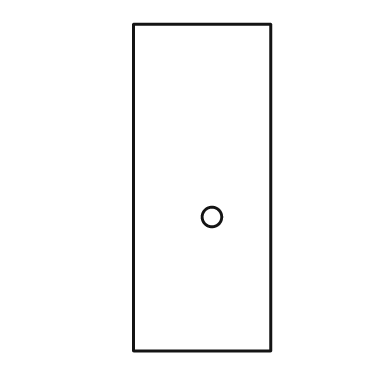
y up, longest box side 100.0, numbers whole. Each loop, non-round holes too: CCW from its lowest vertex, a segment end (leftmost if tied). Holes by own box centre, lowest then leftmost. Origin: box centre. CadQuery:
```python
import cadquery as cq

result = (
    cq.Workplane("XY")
    .moveTo(-21.0, -50.0)
    .lineTo(21.0, -50.0)
    .lineTo(21.0, 50.0)
    .lineTo(-21.0, 50.0)
    .close()
    .moveTo(3.0, -9.0)
    .circle(3.0)
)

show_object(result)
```